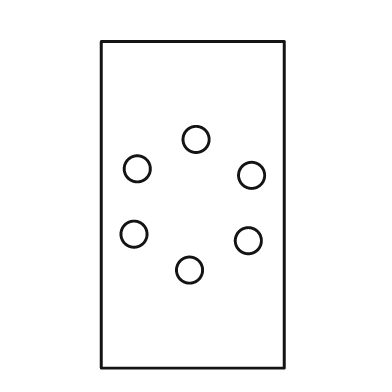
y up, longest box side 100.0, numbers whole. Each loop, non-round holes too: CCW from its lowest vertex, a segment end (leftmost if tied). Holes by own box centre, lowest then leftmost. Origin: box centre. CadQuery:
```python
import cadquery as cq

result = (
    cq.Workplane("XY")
    .moveTo(-28.0, -50.0)
    .lineTo(28.0, -50.0)
    .lineTo(28.0, 50.0)
    .lineTo(-28.0, 50.0)
    .close()
    .moveTo(-1.0, -20.0)
    .circle(4.0)
    .moveTo(17.0, -11.0)
    .circle(4.0)
    .moveTo(-18.0, -9.0)
    .circle(4.0)
    .moveTo(18.0, 9.0)
    .circle(4.0)
    .moveTo(-17.0, 11.0)
    .circle(4.0)
    .moveTo(1.0, 20.0)
    .circle(4.0)
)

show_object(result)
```